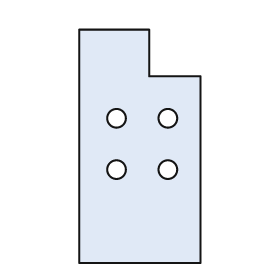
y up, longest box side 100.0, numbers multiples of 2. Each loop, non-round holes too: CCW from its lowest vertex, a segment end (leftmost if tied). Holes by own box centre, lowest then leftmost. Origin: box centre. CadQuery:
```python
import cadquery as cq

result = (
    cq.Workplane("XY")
    .moveTo(-26.0, -50.0)
    .lineTo(26.0, -50.0)
    .lineTo(26.0, 30.0)
    .lineTo(4.0, 30.0)
    .lineTo(4.0, 50.0)
    .lineTo(-26.0, 50.0)
    .close()
    .moveTo(-10.0, -10.0)
    .circle(4.0)
    .moveTo(12.0, -10.0)
    .circle(4.0)
    .moveTo(-10.0, 12.0)
    .circle(4.0)
    .moveTo(12.0, 12.0)
    .circle(4.0)
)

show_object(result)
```